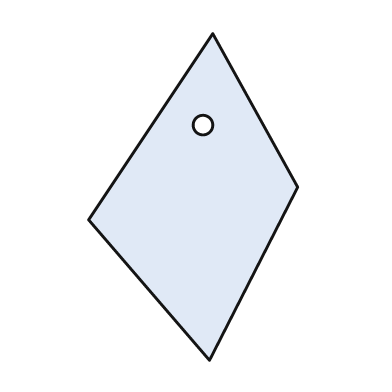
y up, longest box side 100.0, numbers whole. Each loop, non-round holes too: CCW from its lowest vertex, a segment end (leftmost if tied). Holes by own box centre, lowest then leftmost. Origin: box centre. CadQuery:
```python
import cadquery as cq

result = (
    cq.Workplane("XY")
    .moveTo(5.0, -50.0)
    .lineTo(32.0, 3.0)
    .lineTo(6.0, 50.0)
    .lineTo(-32.0, -7.0)
    .close()
    .moveTo(3.0, 22.0)
    .circle(3.0)
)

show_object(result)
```